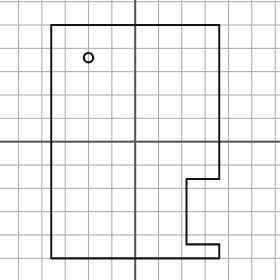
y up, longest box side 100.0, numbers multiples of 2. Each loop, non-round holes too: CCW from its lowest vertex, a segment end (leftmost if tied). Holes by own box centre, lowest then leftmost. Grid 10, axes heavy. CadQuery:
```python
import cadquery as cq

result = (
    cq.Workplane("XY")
    .moveTo(-36.0, -50.0)
    .lineTo(36.0, -50.0)
    .lineTo(36.0, -44.0)
    .lineTo(22.0, -44.0)
    .lineTo(22.0, -16.0)
    .lineTo(36.0, -16.0)
    .lineTo(36.0, 50.0)
    .lineTo(-36.0, 50.0)
    .close()
    .moveTo(-20.0, 36.0)
    .circle(2.0)
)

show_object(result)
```